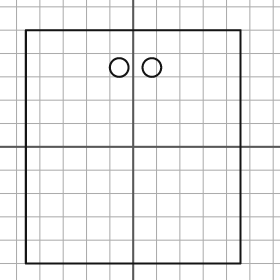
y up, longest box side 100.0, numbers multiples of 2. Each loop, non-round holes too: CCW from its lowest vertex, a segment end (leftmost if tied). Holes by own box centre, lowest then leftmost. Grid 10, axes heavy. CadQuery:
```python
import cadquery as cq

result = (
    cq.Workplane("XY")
    .moveTo(-46.0, -50.0)
    .lineTo(46.0, -50.0)
    .lineTo(46.0, 50.0)
    .lineTo(-46.0, 50.0)
    .close()
    .moveTo(-6.0, 34.0)
    .circle(4.0)
    .moveTo(8.0, 34.0)
    .circle(4.0)
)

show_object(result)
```